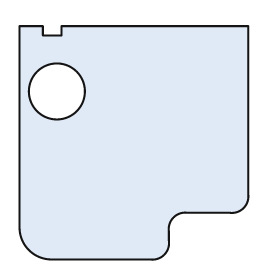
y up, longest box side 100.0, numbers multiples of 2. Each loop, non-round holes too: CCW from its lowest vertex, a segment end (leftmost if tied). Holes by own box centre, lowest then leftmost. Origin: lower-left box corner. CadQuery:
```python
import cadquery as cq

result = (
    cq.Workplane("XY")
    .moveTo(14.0, 0.0)
    .lineTo(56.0, 0.0)
    .threePointArc((62.0, 2.0), (64.0, 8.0))
    .lineTo(64.0, 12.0)
    .threePointArc((66.0, 18.0), (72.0, 20.0))
    .lineTo(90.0, 20.0)
    .threePointArc((96.0, 22.0), (98.0, 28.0))
    .lineTo(98.0, 100.0)
    .lineTo(18.0, 100.0)
    .lineTo(18.0, 96.0)
    .lineTo(10.0, 96.0)
    .lineTo(10.0, 100.0)
    .lineTo(0.0, 100.0)
    .lineTo(0.0, 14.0)
    .threePointArc((4.0, 4.0), (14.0, 0.0))
    .close()
    .moveTo(16.0, 72.0)
    .circle(12.0)
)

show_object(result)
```